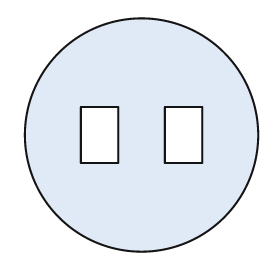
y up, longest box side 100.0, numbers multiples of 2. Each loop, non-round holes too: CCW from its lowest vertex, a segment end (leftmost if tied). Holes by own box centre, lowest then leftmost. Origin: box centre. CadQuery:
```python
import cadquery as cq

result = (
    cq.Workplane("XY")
    .moveTo(0.0, 0.0)
    .circle(50.0)
    .moveTo(-26.0, -12.0)
    .lineTo(-10.0, -12.0)
    .lineTo(-10.0, 12.0)
    .lineTo(-26.0, 12.0)
    .close()
    .moveTo(10.0, -12.0)
    .lineTo(26.0, -12.0)
    .lineTo(26.0, 12.0)
    .lineTo(10.0, 12.0)
    .close()
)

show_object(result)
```